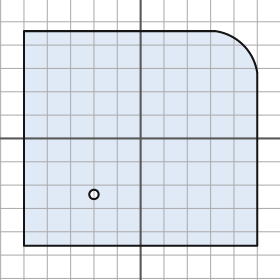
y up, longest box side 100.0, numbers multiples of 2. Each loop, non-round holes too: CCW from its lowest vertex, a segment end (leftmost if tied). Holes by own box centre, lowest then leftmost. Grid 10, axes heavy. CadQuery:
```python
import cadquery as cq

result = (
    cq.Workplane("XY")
    .moveTo(-50.0, -46.0)
    .lineTo(50.0, -46.0)
    .lineTo(50.0, 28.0)
    .threePointArc((44.0, 40.0), (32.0, 46.0))
    .lineTo(-50.0, 46.0)
    .close()
    .moveTo(-20.0, -24.0)
    .circle(2.0)
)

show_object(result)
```